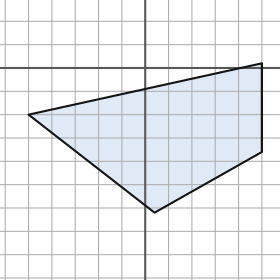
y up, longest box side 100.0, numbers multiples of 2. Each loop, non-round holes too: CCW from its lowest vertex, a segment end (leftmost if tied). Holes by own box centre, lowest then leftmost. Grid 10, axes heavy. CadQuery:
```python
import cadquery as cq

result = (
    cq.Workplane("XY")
    .moveTo(4.0, -62.0)
    .lineTo(50.0, -36.0)
    .lineTo(50.0, 2.0)
    .lineTo(-50.0, -20.0)
    .close()
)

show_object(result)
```